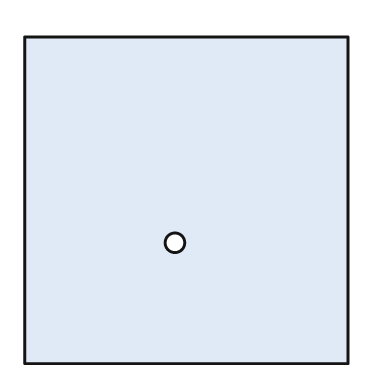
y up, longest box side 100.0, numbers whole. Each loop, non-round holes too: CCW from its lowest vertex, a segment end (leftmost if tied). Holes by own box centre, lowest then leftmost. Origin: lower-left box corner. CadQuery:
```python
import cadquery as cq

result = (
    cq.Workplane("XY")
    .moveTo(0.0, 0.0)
    .lineTo(99.0, 0.0)
    .lineTo(99.0, 100.0)
    .lineTo(0.0, 100.0)
    .close()
    .moveTo(46.0, 37.0)
    .circle(3.0)
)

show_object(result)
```